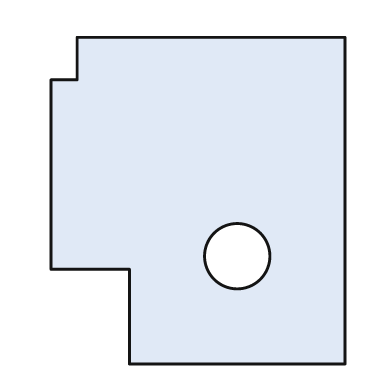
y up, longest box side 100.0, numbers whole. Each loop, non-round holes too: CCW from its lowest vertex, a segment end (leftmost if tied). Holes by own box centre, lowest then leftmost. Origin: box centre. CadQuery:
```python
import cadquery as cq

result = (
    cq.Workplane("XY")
    .moveTo(-21.0, -50.0)
    .lineTo(45.0, -50.0)
    .lineTo(45.0, 50.0)
    .lineTo(-37.0, 50.0)
    .lineTo(-37.0, 37.0)
    .lineTo(-45.0, 37.0)
    .lineTo(-45.0, -21.0)
    .lineTo(-21.0, -21.0)
    .close()
    .moveTo(12.0, -17.0)
    .circle(10.0)
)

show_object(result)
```